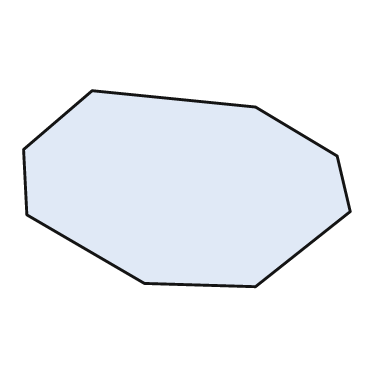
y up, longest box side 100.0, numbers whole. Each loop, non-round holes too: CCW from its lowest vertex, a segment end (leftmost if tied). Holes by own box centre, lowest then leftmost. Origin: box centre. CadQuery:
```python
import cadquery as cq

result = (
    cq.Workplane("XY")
    .moveTo(21.0, -30.0)
    .lineTo(50.0, -7.0)
    .lineTo(46.0, 10.0)
    .lineTo(21.0, 25.0)
    .lineTo(-29.0, 30.0)
    .lineTo(-50.0, 12.0)
    .lineTo(-49.0, -8.0)
    .lineTo(-13.0, -29.0)
    .close()
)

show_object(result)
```